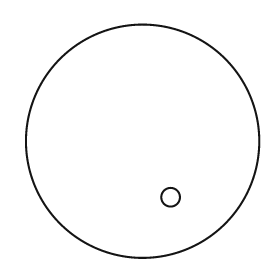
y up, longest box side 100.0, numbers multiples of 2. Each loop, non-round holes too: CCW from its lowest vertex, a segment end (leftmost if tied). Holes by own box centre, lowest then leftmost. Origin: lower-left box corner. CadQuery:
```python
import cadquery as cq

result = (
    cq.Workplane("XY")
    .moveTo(50.0, 50.0)
    .circle(50.0)
    .moveTo(62.0, 26.0)
    .circle(4.0)
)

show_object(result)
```